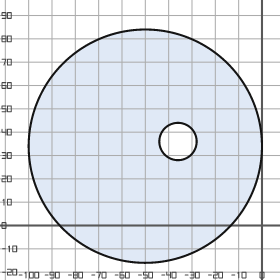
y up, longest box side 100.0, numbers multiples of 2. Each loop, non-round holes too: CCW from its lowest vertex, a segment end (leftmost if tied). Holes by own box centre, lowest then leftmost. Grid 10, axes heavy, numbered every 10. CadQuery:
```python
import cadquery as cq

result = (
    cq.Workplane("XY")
    .moveTo(-50.0, 34.0)
    .circle(50.0)
    .moveTo(-36.0, 36.0)
    .circle(8.0)
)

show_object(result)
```